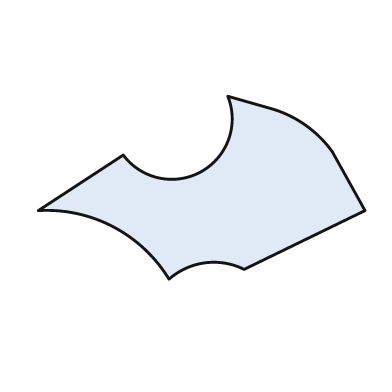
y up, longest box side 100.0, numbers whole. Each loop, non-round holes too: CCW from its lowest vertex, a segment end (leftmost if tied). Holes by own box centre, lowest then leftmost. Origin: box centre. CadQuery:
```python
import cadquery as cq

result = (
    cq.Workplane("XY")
    .moveTo(-10.0, -28.0)
    .threePointArc((1.0, -23.0), (13.0, -25.0))
    .lineTo(50.0, -7.0)
    .lineTo(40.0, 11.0)
    .threePointArc((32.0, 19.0), (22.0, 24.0))
    .lineTo(8.0, 28.0)
    .threePointArc((0.0, 5.0), (-24.0, 10.0))
    .lineTo(-50.0, -7.0)
    .threePointArc((-27.0, -12.0), (-10.0, -28.0))
    .close()
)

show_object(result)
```